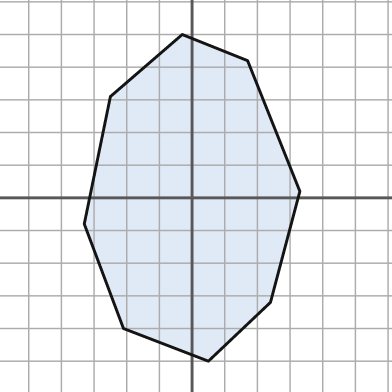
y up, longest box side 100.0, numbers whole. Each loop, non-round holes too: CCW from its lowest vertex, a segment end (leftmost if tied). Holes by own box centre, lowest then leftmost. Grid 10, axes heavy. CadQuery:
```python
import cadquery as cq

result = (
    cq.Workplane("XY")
    .moveTo(5.0, -50.0)
    .lineTo(24.0, -32.0)
    .lineTo(33.0, 2.0)
    .lineTo(17.0, 42.0)
    .lineTo(-3.0, 50.0)
    .lineTo(-25.0, 31.0)
    .lineTo(-33.0, -8.0)
    .lineTo(-21.0, -40.0)
    .close()
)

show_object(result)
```